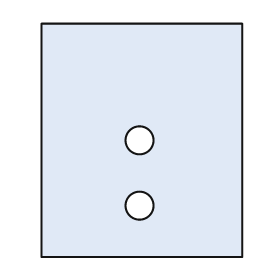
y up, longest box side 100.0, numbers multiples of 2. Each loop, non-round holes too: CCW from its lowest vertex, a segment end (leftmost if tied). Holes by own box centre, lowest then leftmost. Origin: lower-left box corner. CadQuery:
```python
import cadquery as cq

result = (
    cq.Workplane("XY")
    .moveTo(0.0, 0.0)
    .lineTo(86.0, 0.0)
    .lineTo(86.0, 100.0)
    .lineTo(0.0, 100.0)
    .close()
    .moveTo(42.0, 22.0)
    .circle(6.0)
    .moveTo(42.0, 50.0)
    .circle(6.0)
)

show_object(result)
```